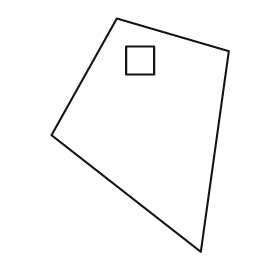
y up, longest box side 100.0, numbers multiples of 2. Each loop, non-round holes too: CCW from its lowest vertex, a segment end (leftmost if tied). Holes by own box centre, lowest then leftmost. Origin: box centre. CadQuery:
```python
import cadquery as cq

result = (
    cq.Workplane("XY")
    .moveTo(26.0, -50.0)
    .lineTo(38.0, 36.0)
    .lineTo(-10.0, 50.0)
    .lineTo(-38.0, 0.0)
    .close()
    .moveTo(-6.0, 26.0)
    .lineTo(6.0, 26.0)
    .lineTo(6.0, 38.0)
    .lineTo(-6.0, 38.0)
    .close()
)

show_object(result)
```